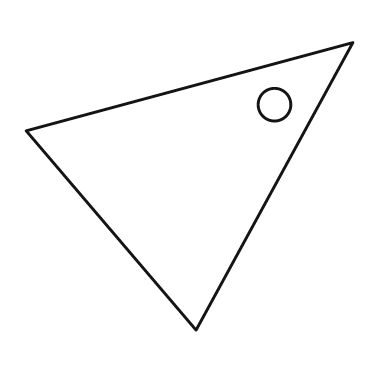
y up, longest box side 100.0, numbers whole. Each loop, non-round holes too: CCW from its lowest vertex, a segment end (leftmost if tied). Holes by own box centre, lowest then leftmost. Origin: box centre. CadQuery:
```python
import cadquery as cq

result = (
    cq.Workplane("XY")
    .moveTo(2.0, -44.0)
    .lineTo(50.0, 44.0)
    .lineTo(-50.0, 17.0)
    .close()
    .moveTo(26.0, 25.0)
    .circle(5.0)
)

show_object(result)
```